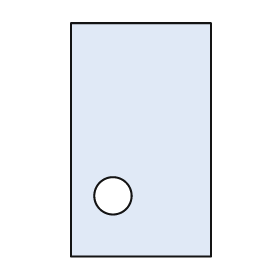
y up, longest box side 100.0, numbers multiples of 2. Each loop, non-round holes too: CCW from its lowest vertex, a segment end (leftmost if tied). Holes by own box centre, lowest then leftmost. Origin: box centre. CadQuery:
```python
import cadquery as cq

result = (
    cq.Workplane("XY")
    .moveTo(-30.0, -50.0)
    .lineTo(30.0, -50.0)
    .lineTo(30.0, 50.0)
    .lineTo(-30.0, 50.0)
    .close()
    .moveTo(-12.0, -24.0)
    .circle(8.0)
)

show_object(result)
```